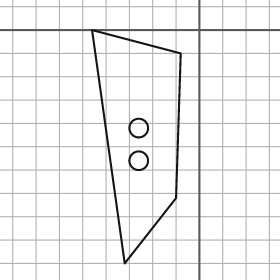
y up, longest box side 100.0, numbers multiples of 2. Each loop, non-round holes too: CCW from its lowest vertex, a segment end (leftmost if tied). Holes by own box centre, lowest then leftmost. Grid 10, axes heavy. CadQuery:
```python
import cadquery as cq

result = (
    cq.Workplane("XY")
    .moveTo(-32.0, -100.0)
    .lineTo(-10.0, -72.0)
    .lineTo(-8.0, -10.0)
    .lineTo(-46.0, 0.0)
    .close()
    .moveTo(-26.0, -56.0)
    .circle(4.0)
    .moveTo(-26.0, -42.0)
    .circle(4.0)
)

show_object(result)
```